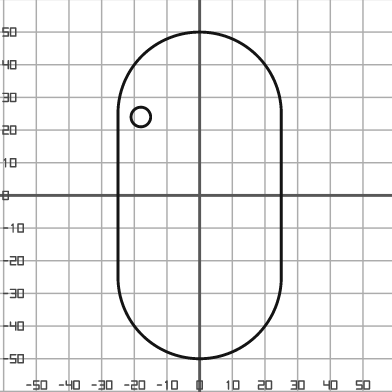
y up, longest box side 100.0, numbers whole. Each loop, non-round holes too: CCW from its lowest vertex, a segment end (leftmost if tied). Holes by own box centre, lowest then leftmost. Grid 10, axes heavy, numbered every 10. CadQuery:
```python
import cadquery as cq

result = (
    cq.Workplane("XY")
    .moveTo(-25.0, -25.0)
    .threePointArc((0.0, -50.0), (25.0, -25.0))
    .lineTo(25.0, 25.0)
    .threePointArc((0.0, 50.0), (-25.0, 25.0))
    .close()
    .moveTo(-18.0, 24.0)
    .circle(3.0)
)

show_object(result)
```